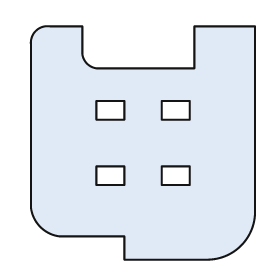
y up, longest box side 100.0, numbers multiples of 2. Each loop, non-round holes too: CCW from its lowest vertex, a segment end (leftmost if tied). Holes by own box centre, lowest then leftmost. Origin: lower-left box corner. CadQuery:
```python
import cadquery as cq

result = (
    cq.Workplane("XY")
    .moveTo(40.0, 0.0)
    .lineTo(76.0, 0.0)
    .threePointArc((90.0, 6.0), (96.0, 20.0))
    .lineTo(96.0, 100.0)
    .lineTo(70.0, 100.0)
    .lineTo(70.0, 82.0)
    .lineTo(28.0, 82.0)
    .threePointArc((24.0, 84.0), (22.0, 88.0))
    .lineTo(22.0, 100.0)
    .lineTo(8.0, 100.0)
    .threePointArc((2.0, 98.0), (0.0, 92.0))
    .lineTo(0.0, 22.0)
    .threePointArc((4.0, 14.0), (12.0, 10.0))
    .lineTo(40.0, 10.0)
    .close()
    .moveTo(28.0, 32.0)
    .lineTo(40.0, 32.0)
    .lineTo(40.0, 40.0)
    .lineTo(28.0, 40.0)
    .close()
    .moveTo(56.0, 32.0)
    .lineTo(68.0, 32.0)
    .lineTo(68.0, 40.0)
    .lineTo(56.0, 40.0)
    .close()
    .moveTo(28.0, 60.0)
    .lineTo(40.0, 60.0)
    .lineTo(40.0, 68.0)
    .lineTo(28.0, 68.0)
    .close()
    .moveTo(56.0, 60.0)
    .lineTo(68.0, 60.0)
    .lineTo(68.0, 68.0)
    .lineTo(56.0, 68.0)
    .close()
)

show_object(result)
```